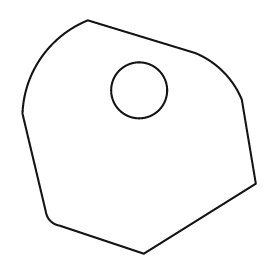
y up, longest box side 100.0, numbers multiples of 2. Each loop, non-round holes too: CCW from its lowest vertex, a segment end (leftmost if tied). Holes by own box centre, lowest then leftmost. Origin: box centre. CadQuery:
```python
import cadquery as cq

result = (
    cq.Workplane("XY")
    .moveTo(2.0, -50.0)
    .lineTo(50.0, -20.0)
    .lineTo(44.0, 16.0)
    .threePointArc((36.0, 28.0), (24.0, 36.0))
    .lineTo(-22.0, 50.0)
    .threePointArc((-42.0, 34.0), (-50.0, 10.0))
    .lineTo(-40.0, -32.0)
    .threePointArc((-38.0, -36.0), (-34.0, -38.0))
    .close()
    .moveTo(0.0, 20.0)
    .circle(12.0)
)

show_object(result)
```